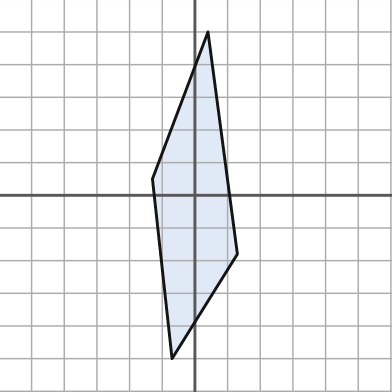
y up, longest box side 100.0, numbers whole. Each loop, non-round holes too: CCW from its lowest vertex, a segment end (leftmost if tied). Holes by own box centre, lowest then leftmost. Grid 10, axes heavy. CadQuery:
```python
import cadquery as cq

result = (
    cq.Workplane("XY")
    .moveTo(-7.0, -50.0)
    .lineTo(13.0, -18.0)
    .lineTo(4.0, 50.0)
    .lineTo(-13.0, 5.0)
    .close()
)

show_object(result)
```